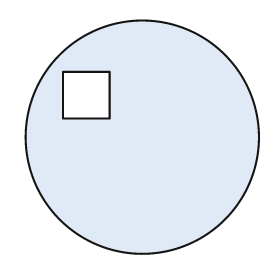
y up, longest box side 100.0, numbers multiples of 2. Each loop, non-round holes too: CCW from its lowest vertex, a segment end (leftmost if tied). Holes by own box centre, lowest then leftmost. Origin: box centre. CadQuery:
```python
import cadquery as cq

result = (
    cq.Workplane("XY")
    .moveTo(0.0, 0.0)
    .circle(50.0)
    .moveTo(-34.0, 8.0)
    .lineTo(-14.0, 8.0)
    .lineTo(-14.0, 28.0)
    .lineTo(-34.0, 28.0)
    .close()
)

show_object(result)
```